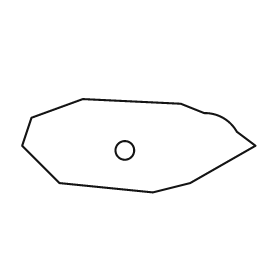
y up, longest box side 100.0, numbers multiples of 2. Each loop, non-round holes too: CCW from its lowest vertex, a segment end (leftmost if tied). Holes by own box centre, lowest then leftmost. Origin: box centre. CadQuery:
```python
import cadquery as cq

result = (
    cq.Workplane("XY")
    .moveTo(6.0, -20.0)
    .lineTo(22.0, -16.0)
    .lineTo(50.0, 0.0)
    .lineTo(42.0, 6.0)
    .threePointArc((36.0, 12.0), (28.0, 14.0))
    .lineTo(18.0, 18.0)
    .lineTo(-24.0, 20.0)
    .lineTo(-46.0, 12.0)
    .lineTo(-50.0, 0.0)
    .lineTo(-34.0, -16.0)
    .close()
    .moveTo(-6.0, -2.0)
    .circle(4.0)
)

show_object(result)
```